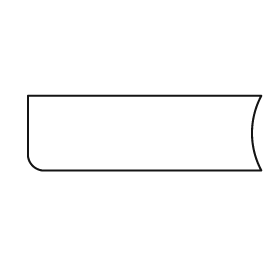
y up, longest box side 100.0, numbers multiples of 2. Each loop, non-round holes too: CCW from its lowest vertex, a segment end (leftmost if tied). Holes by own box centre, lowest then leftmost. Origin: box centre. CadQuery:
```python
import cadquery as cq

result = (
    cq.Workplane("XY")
    .moveTo(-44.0, -16.0)
    .lineTo(50.0, -16.0)
    .threePointArc((46.0, 0.0), (50.0, 16.0))
    .lineTo(-50.0, 16.0)
    .lineTo(-50.0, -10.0)
    .threePointArc((-48.0, -14.0), (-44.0, -16.0))
    .close()
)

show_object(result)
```